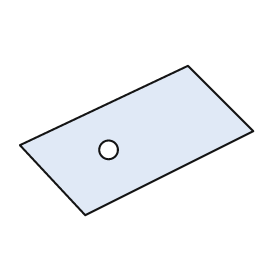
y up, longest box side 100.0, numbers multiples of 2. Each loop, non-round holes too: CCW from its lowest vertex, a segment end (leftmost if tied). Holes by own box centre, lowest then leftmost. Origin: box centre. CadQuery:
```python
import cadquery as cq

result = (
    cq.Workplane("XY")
    .moveTo(-22.0, -32.0)
    .lineTo(50.0, 4.0)
    .lineTo(22.0, 32.0)
    .lineTo(-50.0, -2.0)
    .close()
    .moveTo(-12.0, -4.0)
    .circle(4.0)
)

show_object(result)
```